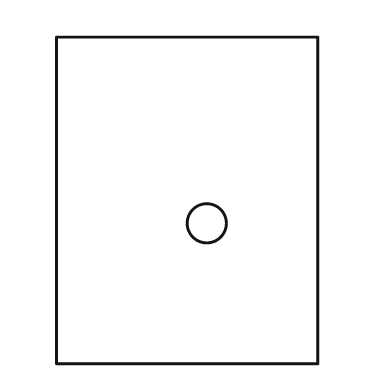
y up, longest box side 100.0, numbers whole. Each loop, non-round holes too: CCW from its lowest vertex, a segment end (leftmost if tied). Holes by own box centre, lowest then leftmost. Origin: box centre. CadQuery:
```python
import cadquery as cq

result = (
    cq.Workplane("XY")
    .moveTo(-40.0, -50.0)
    .lineTo(40.0, -50.0)
    .lineTo(40.0, 50.0)
    .lineTo(-40.0, 50.0)
    .close()
    .moveTo(6.0, -7.0)
    .circle(6.0)
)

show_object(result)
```